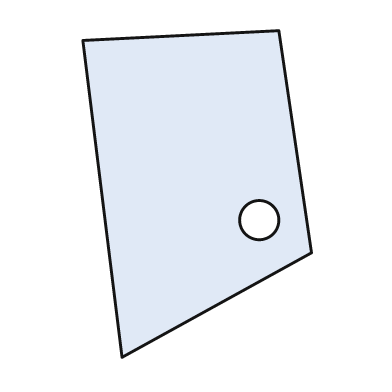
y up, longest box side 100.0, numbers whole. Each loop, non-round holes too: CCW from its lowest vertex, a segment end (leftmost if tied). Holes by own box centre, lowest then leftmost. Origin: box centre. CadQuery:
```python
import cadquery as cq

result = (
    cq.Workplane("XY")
    .moveTo(-23.0, -50.0)
    .lineTo(35.0, -18.0)
    .lineTo(25.0, 50.0)
    .lineTo(-35.0, 47.0)
    .close()
    .moveTo(19.0, -8.0)
    .circle(6.0)
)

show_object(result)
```